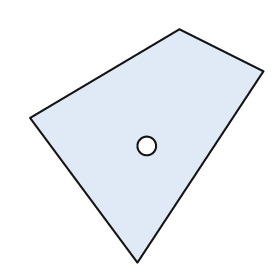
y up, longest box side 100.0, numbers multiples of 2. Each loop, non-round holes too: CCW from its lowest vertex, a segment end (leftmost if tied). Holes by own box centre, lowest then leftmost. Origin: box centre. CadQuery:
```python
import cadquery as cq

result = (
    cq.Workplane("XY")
    .moveTo(-4.0, -50.0)
    .lineTo(50.0, 32.0)
    .lineTo(14.0, 50.0)
    .lineTo(-50.0, 12.0)
    .close()
    .moveTo(0.0, 0.0)
    .circle(4.0)
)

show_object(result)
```